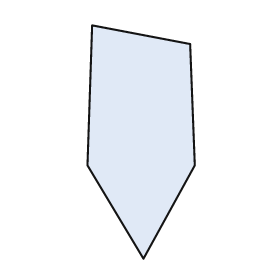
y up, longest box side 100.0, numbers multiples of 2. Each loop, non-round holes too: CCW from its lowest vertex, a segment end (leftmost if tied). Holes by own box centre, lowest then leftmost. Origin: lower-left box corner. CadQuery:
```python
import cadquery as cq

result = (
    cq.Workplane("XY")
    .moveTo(24.0, 0.0)
    .lineTo(46.0, 40.0)
    .lineTo(44.0, 92.0)
    .lineTo(2.0, 100.0)
    .lineTo(0.0, 40.0)
    .close()
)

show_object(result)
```